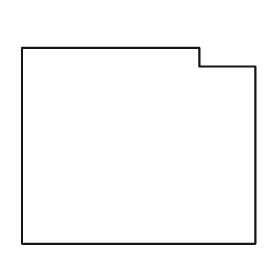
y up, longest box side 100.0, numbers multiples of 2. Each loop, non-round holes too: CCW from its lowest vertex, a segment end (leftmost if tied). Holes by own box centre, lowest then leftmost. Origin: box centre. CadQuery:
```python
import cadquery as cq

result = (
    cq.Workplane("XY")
    .moveTo(-50.0, -42.0)
    .lineTo(50.0, -42.0)
    .lineTo(50.0, 34.0)
    .lineTo(26.0, 34.0)
    .lineTo(26.0, 42.0)
    .lineTo(-50.0, 42.0)
    .close()
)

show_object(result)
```